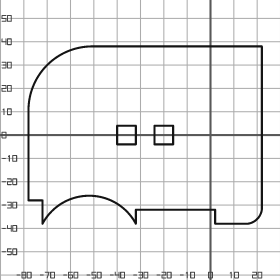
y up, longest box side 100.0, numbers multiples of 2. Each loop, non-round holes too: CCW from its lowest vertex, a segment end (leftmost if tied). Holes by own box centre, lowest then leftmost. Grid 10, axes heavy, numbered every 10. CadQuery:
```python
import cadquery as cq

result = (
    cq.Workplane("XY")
    .moveTo(-72.0, -38.0)
    .threePointArc((-52.0, -26.0), (-32.0, -38.0))
    .lineTo(-32.0, -32.0)
    .lineTo(2.0, -32.0)
    .lineTo(2.0, -38.0)
    .lineTo(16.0, -38.0)
    .threePointArc((20.0, -36.0), (22.0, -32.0))
    .lineTo(22.0, 38.0)
    .lineTo(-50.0, 38.0)
    .threePointArc((-70.0, 30.0), (-78.0, 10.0))
    .lineTo(-78.0, -28.0)
    .lineTo(-72.0, -28.0)
    .close()
    .moveTo(-40.0, -4.0)
    .lineTo(-32.0, -4.0)
    .lineTo(-32.0, 4.0)
    .lineTo(-40.0, 4.0)
    .close()
    .moveTo(-24.0, -4.0)
    .lineTo(-16.0, -4.0)
    .lineTo(-16.0, 4.0)
    .lineTo(-24.0, 4.0)
    .close()
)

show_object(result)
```